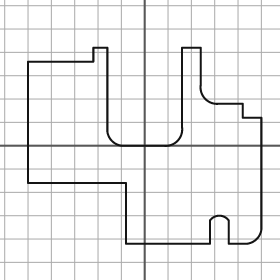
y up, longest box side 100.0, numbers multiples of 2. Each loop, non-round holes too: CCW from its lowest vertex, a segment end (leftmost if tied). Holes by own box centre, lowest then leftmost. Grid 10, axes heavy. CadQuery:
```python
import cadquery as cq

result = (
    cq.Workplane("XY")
    .moveTo(-8.0, -42.0)
    .lineTo(28.0, -42.0)
    .lineTo(28.0, -32.0)
    .threePointArc((32.0, -30.0), (36.0, -32.0))
    .lineTo(36.0, -42.0)
    .lineTo(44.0, -42.0)
    .threePointArc((48.0, -40.0), (50.0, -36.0))
    .lineTo(50.0, 12.0)
    .lineTo(42.0, 12.0)
    .lineTo(42.0, 18.0)
    .lineTo(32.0, 18.0)
    .threePointArc((26.0, 20.0), (24.0, 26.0))
    .lineTo(24.0, 42.0)
    .lineTo(16.0, 42.0)
    .lineTo(16.0, 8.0)
    .threePointArc((14.0, 2.0), (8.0, 0.0))
    .lineTo(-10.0, 0.0)
    .threePointArc((-14.0, 2.0), (-16.0, 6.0))
    .lineTo(-16.0, 42.0)
    .lineTo(-22.0, 42.0)
    .lineTo(-22.0, 36.0)
    .lineTo(-50.0, 36.0)
    .lineTo(-50.0, -16.0)
    .lineTo(-8.0, -16.0)
    .close()
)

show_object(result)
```